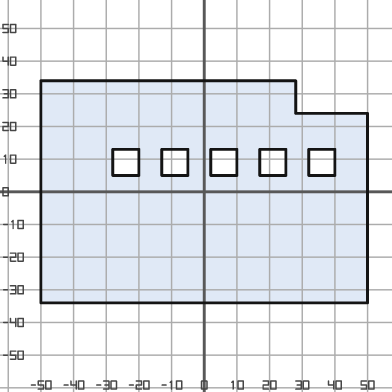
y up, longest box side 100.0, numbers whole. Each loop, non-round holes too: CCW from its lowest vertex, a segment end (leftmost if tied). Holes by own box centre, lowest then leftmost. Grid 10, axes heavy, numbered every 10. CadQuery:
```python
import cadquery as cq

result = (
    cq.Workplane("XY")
    .moveTo(-50.0, -34.0)
    .lineTo(50.0, -34.0)
    .lineTo(50.0, 24.0)
    .lineTo(28.0, 24.0)
    .lineTo(28.0, 34.0)
    .lineTo(-50.0, 34.0)
    .close()
    .moveTo(-28.0, 5.0)
    .lineTo(-20.0, 5.0)
    .lineTo(-20.0, 13.0)
    .lineTo(-28.0, 13.0)
    .close()
    .moveTo(-13.0, 5.0)
    .lineTo(-5.0, 5.0)
    .lineTo(-5.0, 13.0)
    .lineTo(-13.0, 13.0)
    .close()
    .moveTo(2.0, 5.0)
    .lineTo(10.0, 5.0)
    .lineTo(10.0, 13.0)
    .lineTo(2.0, 13.0)
    .close()
    .moveTo(17.0, 5.0)
    .lineTo(25.0, 5.0)
    .lineTo(25.0, 13.0)
    .lineTo(17.0, 13.0)
    .close()
    .moveTo(32.0, 5.0)
    .lineTo(40.0, 5.0)
    .lineTo(40.0, 13.0)
    .lineTo(32.0, 13.0)
    .close()
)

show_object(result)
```